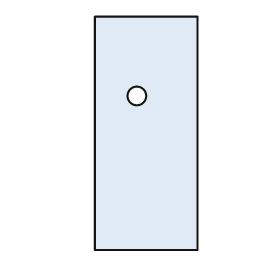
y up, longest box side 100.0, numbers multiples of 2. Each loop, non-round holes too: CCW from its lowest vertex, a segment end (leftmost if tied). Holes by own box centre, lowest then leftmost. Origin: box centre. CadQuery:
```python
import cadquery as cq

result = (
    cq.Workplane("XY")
    .moveTo(-22.0, -50.0)
    .lineTo(22.0, -50.0)
    .lineTo(22.0, 50.0)
    .lineTo(-22.0, 50.0)
    .close()
    .moveTo(-4.0, 16.0)
    .circle(4.0)
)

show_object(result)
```